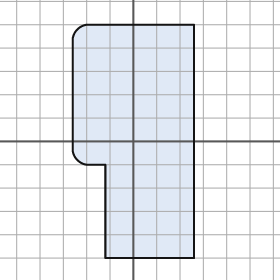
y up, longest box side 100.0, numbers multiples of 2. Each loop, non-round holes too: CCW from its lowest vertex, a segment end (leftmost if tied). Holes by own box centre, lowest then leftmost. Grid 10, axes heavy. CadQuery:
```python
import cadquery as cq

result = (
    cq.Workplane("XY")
    .moveTo(-12.0, -50.0)
    .lineTo(26.0, -50.0)
    .lineTo(26.0, 50.0)
    .lineTo(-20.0, 50.0)
    .threePointArc((-24.0, 48.0), (-26.0, 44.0))
    .lineTo(-26.0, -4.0)
    .threePointArc((-24.0, -8.0), (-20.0, -10.0))
    .lineTo(-12.0, -10.0)
    .close()
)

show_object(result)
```